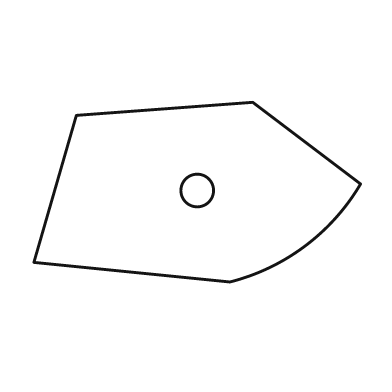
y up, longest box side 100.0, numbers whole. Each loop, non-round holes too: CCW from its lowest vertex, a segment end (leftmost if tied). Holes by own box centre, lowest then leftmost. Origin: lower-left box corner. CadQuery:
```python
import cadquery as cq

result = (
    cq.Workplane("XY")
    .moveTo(60.0, 0.0)
    .threePointArc((83.0, 11.0), (100.0, 30.0))
    .lineTo(67.0, 55.0)
    .lineTo(13.0, 51.0)
    .lineTo(0.0, 6.0)
    .close()
    .moveTo(50.0, 28.0)
    .circle(5.0)
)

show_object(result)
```